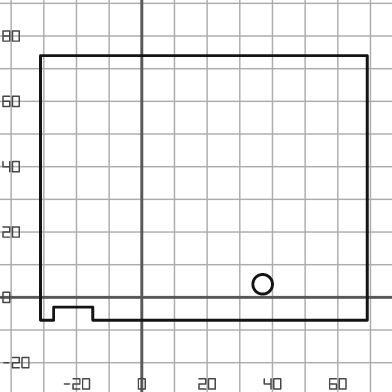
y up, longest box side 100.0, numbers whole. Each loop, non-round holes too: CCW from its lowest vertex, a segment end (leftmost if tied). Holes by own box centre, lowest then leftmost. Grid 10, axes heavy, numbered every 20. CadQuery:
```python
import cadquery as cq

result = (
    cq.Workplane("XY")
    .moveTo(-31.0, -7.0)
    .lineTo(-27.0, -7.0)
    .lineTo(-27.0, -3.0)
    .lineTo(-15.0, -3.0)
    .lineTo(-15.0, -7.0)
    .lineTo(69.0, -7.0)
    .lineTo(69.0, 74.0)
    .lineTo(-31.0, 74.0)
    .close()
    .moveTo(37.0, 4.0)
    .circle(3.0)
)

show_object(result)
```